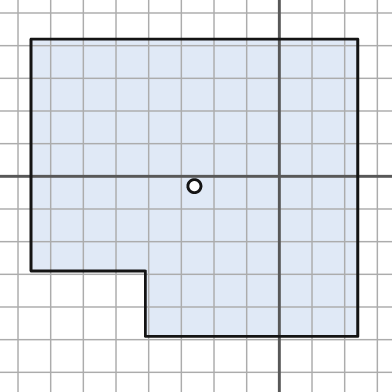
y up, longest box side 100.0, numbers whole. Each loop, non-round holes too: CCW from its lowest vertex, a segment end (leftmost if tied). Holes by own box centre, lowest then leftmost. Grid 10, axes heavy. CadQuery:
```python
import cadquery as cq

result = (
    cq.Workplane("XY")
    .moveTo(-41.0, -49.0)
    .lineTo(24.0, -49.0)
    .lineTo(24.0, 42.0)
    .lineTo(-76.0, 42.0)
    .lineTo(-76.0, -29.0)
    .lineTo(-41.0, -29.0)
    .close()
    .moveTo(-26.0, -3.0)
    .circle(2.0)
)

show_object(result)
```